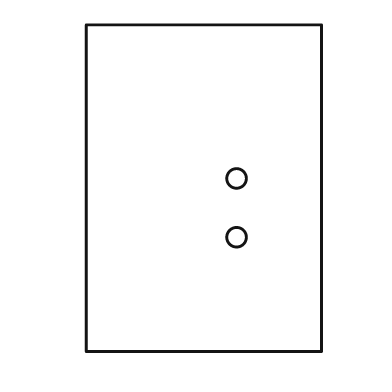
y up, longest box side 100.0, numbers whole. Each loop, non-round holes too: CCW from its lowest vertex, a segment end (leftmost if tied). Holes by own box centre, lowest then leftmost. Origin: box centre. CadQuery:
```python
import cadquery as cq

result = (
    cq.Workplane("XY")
    .moveTo(-36.0, -50.0)
    .lineTo(36.0, -50.0)
    .lineTo(36.0, 50.0)
    .lineTo(-36.0, 50.0)
    .close()
    .moveTo(10.0, -15.0)
    .circle(3.0)
    .moveTo(10.0, 3.0)
    .circle(3.0)
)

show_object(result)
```